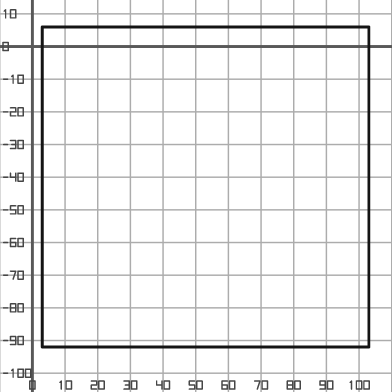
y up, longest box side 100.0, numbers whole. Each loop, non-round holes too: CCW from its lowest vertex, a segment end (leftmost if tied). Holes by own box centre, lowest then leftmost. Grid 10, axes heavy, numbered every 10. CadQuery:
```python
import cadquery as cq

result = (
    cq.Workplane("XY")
    .moveTo(3.0, -92.0)
    .lineTo(103.0, -92.0)
    .lineTo(103.0, 6.0)
    .lineTo(3.0, 6.0)
    .close()
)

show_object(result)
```